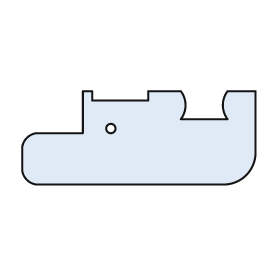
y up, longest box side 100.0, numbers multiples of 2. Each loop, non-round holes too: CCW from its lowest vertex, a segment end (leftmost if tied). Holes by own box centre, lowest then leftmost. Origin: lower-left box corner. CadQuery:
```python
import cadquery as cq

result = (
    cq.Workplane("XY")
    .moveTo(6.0, 0.0)
    .lineTo(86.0, 0.0)
    .threePointArc((96.0, 4.0), (100.0, 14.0))
    .lineTo(100.0, 40.0)
    .lineTo(88.0, 40.0)
    .threePointArc((86.0, 34.0), (88.0, 28.0))
    .lineTo(68.0, 28.0)
    .threePointArc((70.0, 34.0), (68.0, 40.0))
    .lineTo(54.0, 40.0)
    .lineTo(54.0, 36.0)
    .lineTo(30.0, 36.0)
    .lineTo(30.0, 40.0)
    .lineTo(26.0, 40.0)
    .lineTo(26.0, 22.0)
    .lineTo(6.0, 22.0)
    .threePointArc((2.0, 20.0), (0.0, 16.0))
    .lineTo(0.0, 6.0)
    .threePointArc((2.0, 2.0), (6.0, 0.0))
    .close()
    .moveTo(38.0, 24.0)
    .circle(2.0)
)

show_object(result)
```